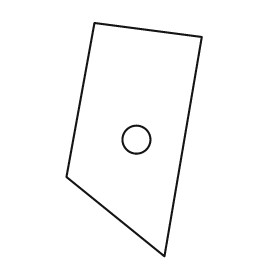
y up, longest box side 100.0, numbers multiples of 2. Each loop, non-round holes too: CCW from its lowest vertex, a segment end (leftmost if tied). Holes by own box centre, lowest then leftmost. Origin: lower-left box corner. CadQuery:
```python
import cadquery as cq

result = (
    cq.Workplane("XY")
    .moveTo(42.0, 0.0)
    .lineTo(58.0, 94.0)
    .lineTo(12.0, 100.0)
    .lineTo(0.0, 34.0)
    .close()
    .moveTo(30.0, 50.0)
    .circle(6.0)
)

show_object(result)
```